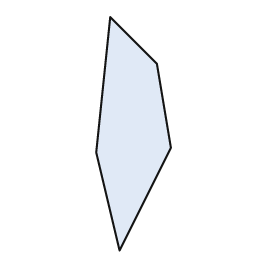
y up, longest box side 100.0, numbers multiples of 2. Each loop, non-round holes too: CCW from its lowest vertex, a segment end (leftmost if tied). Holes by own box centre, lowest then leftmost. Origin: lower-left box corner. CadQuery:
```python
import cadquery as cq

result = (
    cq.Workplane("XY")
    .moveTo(10.0, 0.0)
    .lineTo(32.0, 44.0)
    .lineTo(26.0, 80.0)
    .lineTo(6.0, 100.0)
    .lineTo(0.0, 42.0)
    .close()
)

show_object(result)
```